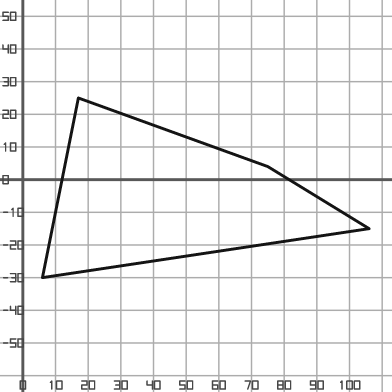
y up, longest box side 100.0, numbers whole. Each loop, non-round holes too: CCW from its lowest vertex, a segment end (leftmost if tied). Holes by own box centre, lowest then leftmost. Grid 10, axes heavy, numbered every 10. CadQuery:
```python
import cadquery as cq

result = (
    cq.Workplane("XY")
    .moveTo(6.0, -30.0)
    .lineTo(106.0, -15.0)
    .lineTo(75.0, 4.0)
    .lineTo(17.0, 25.0)
    .close()
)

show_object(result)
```